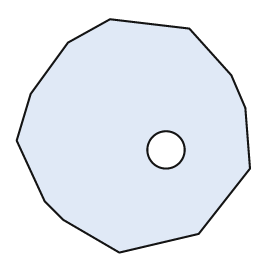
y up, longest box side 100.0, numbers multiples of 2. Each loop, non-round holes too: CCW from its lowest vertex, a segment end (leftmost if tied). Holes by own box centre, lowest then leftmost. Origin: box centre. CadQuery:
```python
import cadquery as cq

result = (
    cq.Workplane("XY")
    .moveTo(-6.0, -50.0)
    .lineTo(28.0, -42.0)
    .lineTo(50.0, -14.0)
    .lineTo(48.0, 12.0)
    .lineTo(42.0, 26.0)
    .lineTo(24.0, 46.0)
    .lineTo(-10.0, 50.0)
    .lineTo(-28.0, 40.0)
    .lineTo(-44.0, 18.0)
    .lineTo(-50.0, -2.0)
    .lineTo(-38.0, -28.0)
    .lineTo(-30.0, -36.0)
    .close()
    .moveTo(14.0, -6.0)
    .circle(8.0)
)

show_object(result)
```